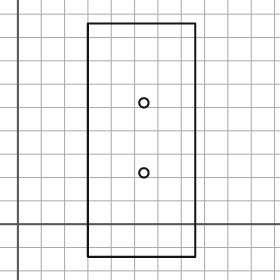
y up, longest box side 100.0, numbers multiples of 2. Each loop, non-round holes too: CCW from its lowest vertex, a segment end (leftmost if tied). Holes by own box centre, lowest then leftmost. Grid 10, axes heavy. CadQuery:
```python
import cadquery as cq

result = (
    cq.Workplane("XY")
    .moveTo(30.0, -14.0)
    .lineTo(76.0, -14.0)
    .lineTo(76.0, 86.0)
    .lineTo(30.0, 86.0)
    .close()
    .moveTo(54.0, 22.0)
    .circle(2.0)
    .moveTo(54.0, 52.0)
    .circle(2.0)
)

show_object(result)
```